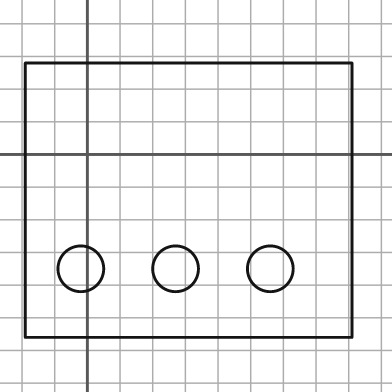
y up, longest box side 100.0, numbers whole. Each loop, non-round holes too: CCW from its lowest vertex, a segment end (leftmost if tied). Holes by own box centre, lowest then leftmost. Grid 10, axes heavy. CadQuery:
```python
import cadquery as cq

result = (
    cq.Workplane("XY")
    .moveTo(-19.0, -56.0)
    .lineTo(81.0, -56.0)
    .lineTo(81.0, 28.0)
    .lineTo(-19.0, 28.0)
    .close()
    .moveTo(-2.0, -35.0)
    .circle(7.0)
    .moveTo(27.0, -35.0)
    .circle(7.0)
    .moveTo(56.0, -35.0)
    .circle(7.0)
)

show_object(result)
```